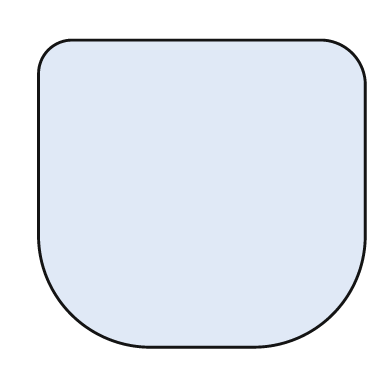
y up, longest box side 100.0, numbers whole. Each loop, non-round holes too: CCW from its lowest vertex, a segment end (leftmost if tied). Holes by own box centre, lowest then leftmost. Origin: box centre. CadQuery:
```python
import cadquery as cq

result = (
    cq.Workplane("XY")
    .moveTo(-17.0, -47.0)
    .lineTo(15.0, -47.0)
    .threePointArc((40.0, -37.0), (50.0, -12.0))
    .lineTo(50.0, 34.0)
    .threePointArc((46.0, 43.0), (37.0, 47.0))
    .lineTo(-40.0, 47.0)
    .threePointArc((-47.0, 44.0), (-50.0, 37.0))
    .lineTo(-50.0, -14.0)
    .threePointArc((-40.0, -37.0), (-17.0, -47.0))
    .close()
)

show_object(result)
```